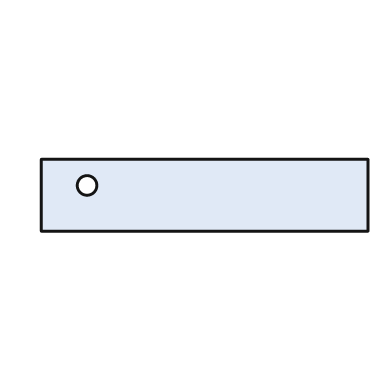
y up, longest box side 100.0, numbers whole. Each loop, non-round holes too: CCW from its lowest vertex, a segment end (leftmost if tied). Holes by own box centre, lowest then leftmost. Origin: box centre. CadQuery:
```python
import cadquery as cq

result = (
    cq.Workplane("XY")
    .moveTo(-50.0, -11.0)
    .lineTo(50.0, -11.0)
    .lineTo(50.0, 11.0)
    .lineTo(-50.0, 11.0)
    .close()
    .moveTo(-36.0, 3.0)
    .circle(3.0)
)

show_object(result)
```